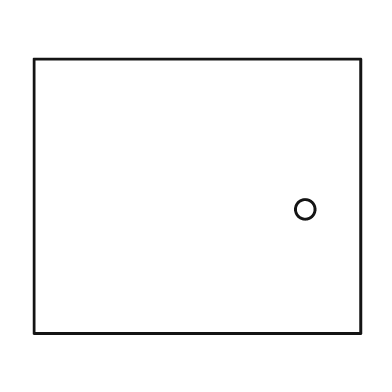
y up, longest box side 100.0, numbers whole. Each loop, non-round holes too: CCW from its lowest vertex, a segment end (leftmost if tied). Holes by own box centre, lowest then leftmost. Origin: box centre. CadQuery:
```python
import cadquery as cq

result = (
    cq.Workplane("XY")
    .moveTo(-50.0, -42.0)
    .lineTo(50.0, -42.0)
    .lineTo(50.0, 42.0)
    .lineTo(-50.0, 42.0)
    .close()
    .moveTo(33.0, -4.0)
    .circle(3.0)
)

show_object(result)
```